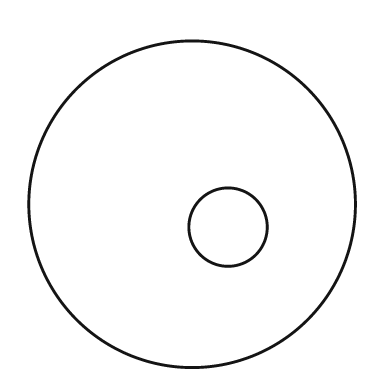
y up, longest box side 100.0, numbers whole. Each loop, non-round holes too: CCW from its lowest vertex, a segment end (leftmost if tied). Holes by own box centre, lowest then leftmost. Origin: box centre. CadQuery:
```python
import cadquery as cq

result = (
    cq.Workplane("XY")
    .moveTo(0.0, 0.0)
    .circle(50.0)
    .moveTo(11.0, -7.0)
    .circle(12.0)
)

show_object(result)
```